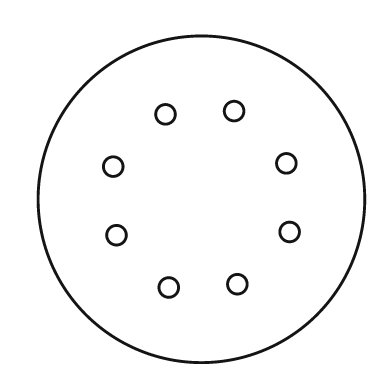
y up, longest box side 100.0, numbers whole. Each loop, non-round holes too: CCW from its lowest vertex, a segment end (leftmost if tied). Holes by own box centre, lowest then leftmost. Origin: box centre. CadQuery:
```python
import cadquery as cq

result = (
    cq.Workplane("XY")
    .moveTo(0.0, 0.0)
    .circle(50.0)
    .moveTo(-10.0, -27.0)
    .circle(3.0)
    .moveTo(11.0, -26.0)
    .circle(3.0)
    .moveTo(-26.0, -11.0)
    .circle(3.0)
    .moveTo(27.0, -10.0)
    .circle(3.0)
    .moveTo(-27.0, 10.0)
    .circle(3.0)
    .moveTo(26.0, 11.0)
    .circle(3.0)
    .moveTo(-11.0, 26.0)
    .circle(3.0)
    .moveTo(10.0, 27.0)
    .circle(3.0)
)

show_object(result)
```